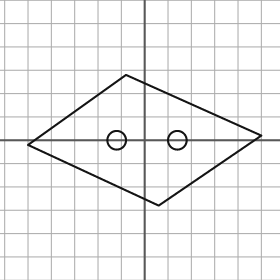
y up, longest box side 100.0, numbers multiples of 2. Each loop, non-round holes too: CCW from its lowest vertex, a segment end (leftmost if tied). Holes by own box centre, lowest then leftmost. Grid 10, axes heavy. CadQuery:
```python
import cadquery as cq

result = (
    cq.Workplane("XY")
    .moveTo(6.0, -28.0)
    .lineTo(50.0, 2.0)
    .lineTo(-8.0, 28.0)
    .lineTo(-50.0, -2.0)
    .close()
    .moveTo(-12.0, 0.0)
    .circle(4.0)
    .moveTo(14.0, 0.0)
    .circle(4.0)
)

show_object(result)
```